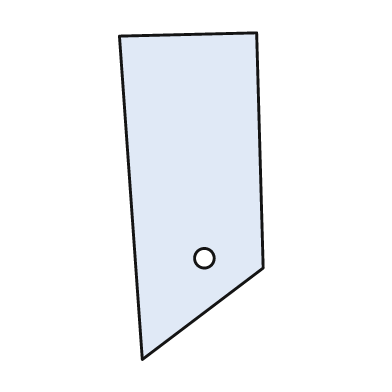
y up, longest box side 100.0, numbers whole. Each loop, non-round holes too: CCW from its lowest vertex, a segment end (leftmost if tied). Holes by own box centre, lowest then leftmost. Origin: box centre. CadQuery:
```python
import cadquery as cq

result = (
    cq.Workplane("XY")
    .moveTo(-15.0, -50.0)
    .lineTo(22.0, -22.0)
    .lineTo(20.0, 50.0)
    .lineTo(-22.0, 49.0)
    .close()
    .moveTo(4.0, -19.0)
    .circle(3.0)
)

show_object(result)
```